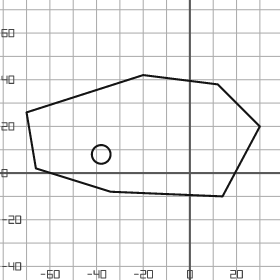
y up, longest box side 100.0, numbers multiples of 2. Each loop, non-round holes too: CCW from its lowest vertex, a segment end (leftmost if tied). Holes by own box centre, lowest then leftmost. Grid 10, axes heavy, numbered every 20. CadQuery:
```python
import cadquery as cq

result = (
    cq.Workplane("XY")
    .moveTo(14.0, -10.0)
    .lineTo(30.0, 20.0)
    .lineTo(12.0, 38.0)
    .lineTo(-20.0, 42.0)
    .lineTo(-70.0, 26.0)
    .lineTo(-66.0, 2.0)
    .lineTo(-34.0, -8.0)
    .close()
    .moveTo(-38.0, 8.0)
    .circle(4.0)
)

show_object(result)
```